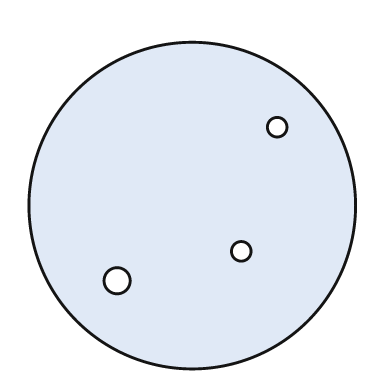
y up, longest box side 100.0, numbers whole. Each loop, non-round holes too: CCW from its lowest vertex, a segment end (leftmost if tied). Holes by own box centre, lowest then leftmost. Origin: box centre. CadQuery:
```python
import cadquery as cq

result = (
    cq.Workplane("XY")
    .moveTo(0.0, 0.0)
    .circle(50.0)
    .moveTo(-23.0, -23.0)
    .circle(4.0)
    .moveTo(15.0, -14.0)
    .circle(3.0)
    .moveTo(26.0, 24.0)
    .circle(3.0)
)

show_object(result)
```